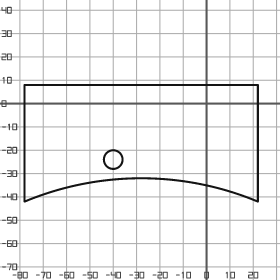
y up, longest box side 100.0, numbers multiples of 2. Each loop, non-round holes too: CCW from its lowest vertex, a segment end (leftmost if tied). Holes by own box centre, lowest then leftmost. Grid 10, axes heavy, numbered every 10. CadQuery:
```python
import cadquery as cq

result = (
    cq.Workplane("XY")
    .moveTo(-78.0, -42.0)
    .threePointArc((-28.0, -32.0), (22.0, -42.0))
    .lineTo(22.0, 8.0)
    .lineTo(-78.0, 8.0)
    .close()
    .moveTo(-40.0, -24.0)
    .circle(4.0)
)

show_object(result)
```